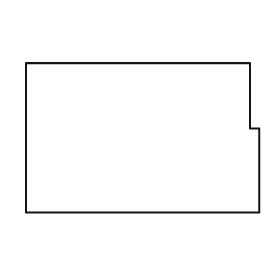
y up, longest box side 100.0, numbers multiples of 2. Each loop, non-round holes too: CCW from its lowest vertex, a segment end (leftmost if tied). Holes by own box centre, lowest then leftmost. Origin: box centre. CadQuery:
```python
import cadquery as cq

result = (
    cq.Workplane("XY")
    .moveTo(-50.0, -32.0)
    .lineTo(50.0, -32.0)
    .lineTo(50.0, 4.0)
    .lineTo(46.0, 4.0)
    .lineTo(46.0, 32.0)
    .lineTo(-50.0, 32.0)
    .close()
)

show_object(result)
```